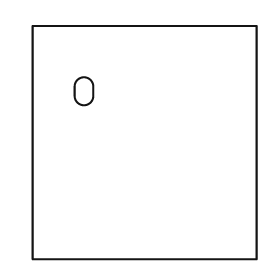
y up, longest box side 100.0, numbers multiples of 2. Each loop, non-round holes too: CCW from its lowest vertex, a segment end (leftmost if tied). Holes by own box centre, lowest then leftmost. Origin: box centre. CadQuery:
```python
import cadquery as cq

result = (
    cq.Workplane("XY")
    .moveTo(-48.0, -50.0)
    .lineTo(48.0, -50.0)
    .lineTo(48.0, 50.0)
    .lineTo(-48.0, 50.0)
    .close()
    .moveTo(-30.0, 20.0)
    .threePointArc((-26.0, 16.0), (-22.0, 20.0))
    .lineTo(-22.0, 24.0)
    .threePointArc((-26.0, 28.0), (-30.0, 24.0))
    .close()
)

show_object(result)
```